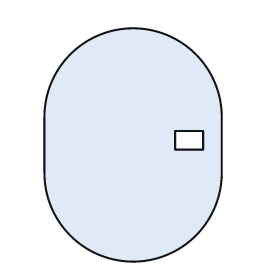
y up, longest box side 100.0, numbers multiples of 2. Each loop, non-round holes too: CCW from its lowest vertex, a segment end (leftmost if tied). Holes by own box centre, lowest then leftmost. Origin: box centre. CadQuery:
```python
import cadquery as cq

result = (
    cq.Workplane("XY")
    .moveTo(-38.0, -12.0)
    .threePointArc((0.0, -50.0), (38.0, -12.0))
    .lineTo(38.0, 12.0)
    .threePointArc((0.0, 50.0), (-38.0, 12.0))
    .close()
    .moveTo(18.0, -2.0)
    .lineTo(30.0, -2.0)
    .lineTo(30.0, 6.0)
    .lineTo(18.0, 6.0)
    .close()
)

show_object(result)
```